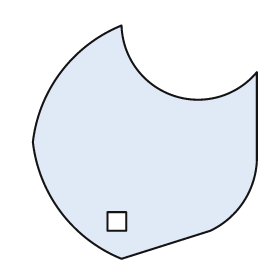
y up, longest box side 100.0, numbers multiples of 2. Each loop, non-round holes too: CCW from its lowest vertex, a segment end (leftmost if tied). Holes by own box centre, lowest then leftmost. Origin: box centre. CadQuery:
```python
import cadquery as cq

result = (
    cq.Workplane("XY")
    .moveTo(-10.0, -50.0)
    .lineTo(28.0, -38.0)
    .threePointArc((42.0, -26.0), (48.0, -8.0))
    .lineTo(48.0, 30.0)
    .threePointArc((12.0, 20.0), (-10.0, 50.0))
    .threePointArc((-36.0, 30.0), (-48.0, 0.0))
    .threePointArc((-36.0, -30.0), (-10.0, -50.0))
    .close()
    .moveTo(-16.0, -38.0)
    .lineTo(-8.0, -38.0)
    .lineTo(-8.0, -30.0)
    .lineTo(-16.0, -30.0)
    .close()
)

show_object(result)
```